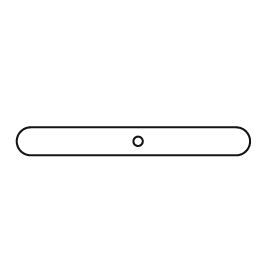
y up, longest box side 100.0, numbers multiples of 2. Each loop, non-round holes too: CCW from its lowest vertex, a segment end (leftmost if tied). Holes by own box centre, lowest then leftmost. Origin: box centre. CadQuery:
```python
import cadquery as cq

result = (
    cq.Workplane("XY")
    .moveTo(-44.0, -6.0)
    .lineTo(44.0, -6.0)
    .threePointArc((50.0, 0.0), (44.0, 6.0))
    .lineTo(-44.0, 6.0)
    .threePointArc((-50.0, 0.0), (-44.0, -6.0))
    .close()
    .moveTo(2.0, 0.0)
    .circle(2.0)
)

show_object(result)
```